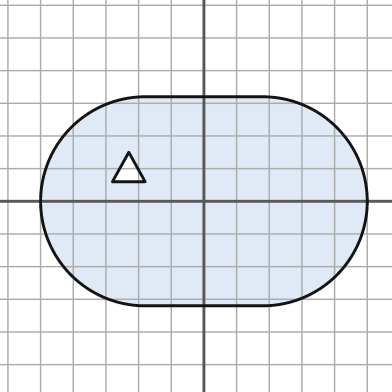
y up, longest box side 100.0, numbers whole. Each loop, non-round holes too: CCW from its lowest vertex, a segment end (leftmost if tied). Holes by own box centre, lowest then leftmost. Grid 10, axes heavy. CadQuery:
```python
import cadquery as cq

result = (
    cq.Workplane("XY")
    .moveTo(-18.0, -32.0)
    .lineTo(18.0, -32.0)
    .threePointArc((50.0, 0.0), (18.0, 32.0))
    .lineTo(-18.0, 32.0)
    .threePointArc((-50.0, 0.0), (-18.0, -32.0))
    .close()
    .moveTo(-28.0, 6.0)
    .lineTo(-18.0, 6.0)
    .lineTo(-23.0, 15.0)
    .close()
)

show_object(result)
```